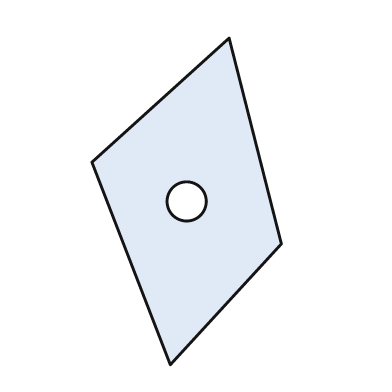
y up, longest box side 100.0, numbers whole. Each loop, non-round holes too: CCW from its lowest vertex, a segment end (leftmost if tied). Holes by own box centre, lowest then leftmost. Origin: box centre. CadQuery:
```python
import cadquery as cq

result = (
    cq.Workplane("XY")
    .moveTo(-5.0, -50.0)
    .lineTo(29.0, -13.0)
    .lineTo(13.0, 50.0)
    .lineTo(-29.0, 12.0)
    .close()
    .moveTo(0.0, 0.0)
    .circle(6.0)
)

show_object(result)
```